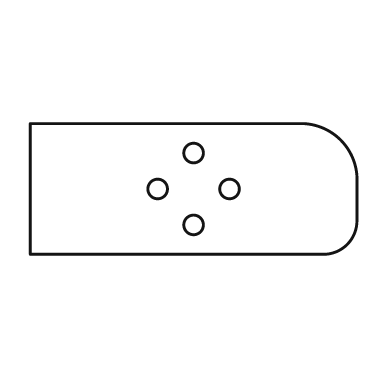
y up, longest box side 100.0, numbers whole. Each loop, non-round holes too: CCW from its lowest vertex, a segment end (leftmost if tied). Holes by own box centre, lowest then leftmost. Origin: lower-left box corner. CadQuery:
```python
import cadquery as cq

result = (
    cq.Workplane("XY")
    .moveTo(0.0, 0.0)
    .lineTo(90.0, 0.0)
    .threePointArc((97.0, 3.0), (100.0, 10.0))
    .lineTo(100.0, 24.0)
    .threePointArc((95.0, 35.0), (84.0, 40.0))
    .lineTo(0.0, 40.0)
    .close()
    .moveTo(50.0, 9.0)
    .circle(3.0)
    .moveTo(39.0, 20.0)
    .circle(3.0)
    .moveTo(61.0, 20.0)
    .circle(3.0)
    .moveTo(50.0, 31.0)
    .circle(3.0)
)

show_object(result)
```